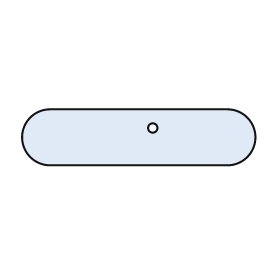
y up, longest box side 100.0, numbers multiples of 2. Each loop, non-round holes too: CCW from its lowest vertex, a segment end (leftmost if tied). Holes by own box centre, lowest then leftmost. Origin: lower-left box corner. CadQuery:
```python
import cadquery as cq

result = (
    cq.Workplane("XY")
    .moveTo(12.0, 0.0)
    .lineTo(88.0, 0.0)
    .threePointArc((100.0, 12.0), (88.0, 24.0))
    .lineTo(12.0, 24.0)
    .threePointArc((0.0, 12.0), (12.0, 0.0))
    .close()
    .moveTo(56.0, 16.0)
    .circle(2.0)
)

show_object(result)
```